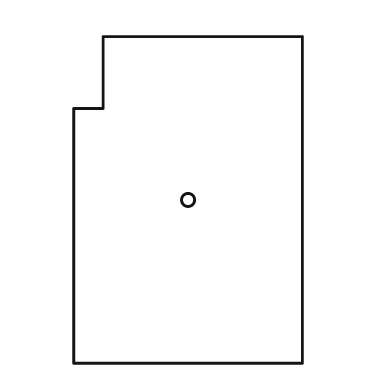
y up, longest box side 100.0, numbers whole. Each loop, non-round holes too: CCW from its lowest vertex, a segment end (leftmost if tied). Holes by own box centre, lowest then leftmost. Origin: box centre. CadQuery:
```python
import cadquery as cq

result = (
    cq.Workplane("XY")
    .moveTo(-35.0, -50.0)
    .lineTo(35.0, -50.0)
    .lineTo(35.0, 50.0)
    .lineTo(-26.0, 50.0)
    .lineTo(-26.0, 28.0)
    .lineTo(-35.0, 28.0)
    .close()
    .moveTo(0.0, 0.0)
    .circle(2.0)
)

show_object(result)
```